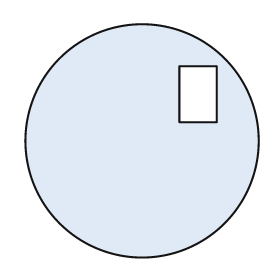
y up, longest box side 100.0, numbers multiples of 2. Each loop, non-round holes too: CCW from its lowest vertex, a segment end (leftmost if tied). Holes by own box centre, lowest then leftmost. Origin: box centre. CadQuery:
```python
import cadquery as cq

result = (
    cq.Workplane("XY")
    .moveTo(0.0, 0.0)
    .circle(50.0)
    .moveTo(16.0, 8.0)
    .lineTo(32.0, 8.0)
    .lineTo(32.0, 32.0)
    .lineTo(16.0, 32.0)
    .close()
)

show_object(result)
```